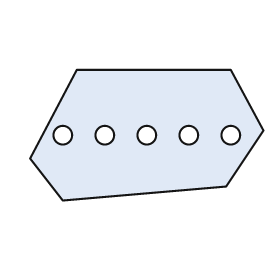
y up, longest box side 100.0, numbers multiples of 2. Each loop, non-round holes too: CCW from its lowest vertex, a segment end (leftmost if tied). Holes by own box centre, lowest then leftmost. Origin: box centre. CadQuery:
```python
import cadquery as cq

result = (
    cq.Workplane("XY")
    .moveTo(-36.0, -28.0)
    .lineTo(34.0, -22.0)
    .lineTo(50.0, 2.0)
    .lineTo(36.0, 28.0)
    .lineTo(-30.0, 28.0)
    .lineTo(-50.0, -10.0)
    .close()
    .moveTo(-36.0, 0.0)
    .circle(4.0)
    .moveTo(-18.0, 0.0)
    .circle(4.0)
    .moveTo(0.0, 0.0)
    .circle(4.0)
    .moveTo(18.0, 0.0)
    .circle(4.0)
    .moveTo(36.0, 0.0)
    .circle(4.0)
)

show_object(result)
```